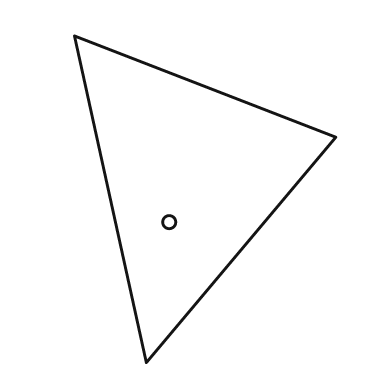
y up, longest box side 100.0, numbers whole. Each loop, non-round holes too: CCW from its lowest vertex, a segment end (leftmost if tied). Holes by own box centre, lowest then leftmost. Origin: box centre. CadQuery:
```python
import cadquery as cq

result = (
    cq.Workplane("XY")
    .moveTo(-18.0, -50.0)
    .lineTo(40.0, 19.0)
    .lineTo(-40.0, 50.0)
    .close()
    .moveTo(-11.0, -7.0)
    .circle(2.0)
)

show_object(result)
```